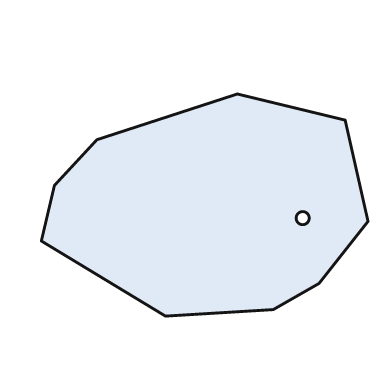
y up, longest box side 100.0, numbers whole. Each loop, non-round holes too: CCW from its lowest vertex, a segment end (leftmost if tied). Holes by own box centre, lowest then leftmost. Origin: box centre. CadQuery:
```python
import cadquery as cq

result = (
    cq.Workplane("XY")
    .moveTo(-12.0, -34.0)
    .lineTo(21.0, -32.0)
    .lineTo(35.0, -24.0)
    .lineTo(50.0, -5.0)
    .lineTo(43.0, 26.0)
    .lineTo(10.0, 34.0)
    .lineTo(-33.0, 20.0)
    .lineTo(-46.0, 6.0)
    .lineTo(-50.0, -11.0)
    .close()
    .moveTo(30.0, -4.0)
    .circle(2.0)
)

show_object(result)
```